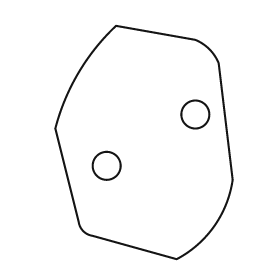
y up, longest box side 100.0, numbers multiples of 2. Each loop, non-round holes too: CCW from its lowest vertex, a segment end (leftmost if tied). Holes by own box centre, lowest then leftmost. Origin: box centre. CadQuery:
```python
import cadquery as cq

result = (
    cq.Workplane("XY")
    .moveTo(14.0, -50.0)
    .threePointArc((30.0, -36.0), (38.0, -16.0))
    .lineTo(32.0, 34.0)
    .threePointArc((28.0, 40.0), (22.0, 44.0))
    .lineTo(-12.0, 50.0)
    .threePointArc((-28.0, 30.0), (-38.0, 6.0))
    .lineTo(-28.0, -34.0)
    .threePointArc((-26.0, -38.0), (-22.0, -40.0))
    .close()
    .moveTo(-16.0, -10.0)
    .circle(6.0)
    .moveTo(22.0, 12.0)
    .circle(6.0)
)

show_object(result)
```